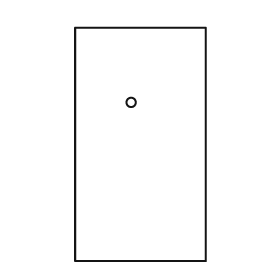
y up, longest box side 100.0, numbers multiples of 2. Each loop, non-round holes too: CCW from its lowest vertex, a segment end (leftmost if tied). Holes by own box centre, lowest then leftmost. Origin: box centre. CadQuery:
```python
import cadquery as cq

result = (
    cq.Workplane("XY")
    .moveTo(-28.0, -50.0)
    .lineTo(28.0, -50.0)
    .lineTo(28.0, 50.0)
    .lineTo(-28.0, 50.0)
    .close()
    .moveTo(-4.0, 18.0)
    .circle(2.0)
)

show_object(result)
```